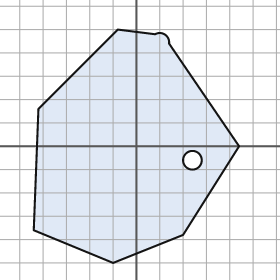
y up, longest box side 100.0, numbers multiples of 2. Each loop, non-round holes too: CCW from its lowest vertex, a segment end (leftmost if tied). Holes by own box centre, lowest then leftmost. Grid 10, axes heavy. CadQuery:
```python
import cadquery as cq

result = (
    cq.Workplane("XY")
    .moveTo(-10.0, -50.0)
    .lineTo(20.0, -38.0)
    .lineTo(44.0, 0.0)
    .lineTo(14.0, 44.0)
    .threePointArc((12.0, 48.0), (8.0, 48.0))
    .lineTo(-8.0, 50.0)
    .lineTo(-42.0, 16.0)
    .lineTo(-44.0, -36.0)
    .close()
    .moveTo(24.0, -6.0)
    .circle(4.0)
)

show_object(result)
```